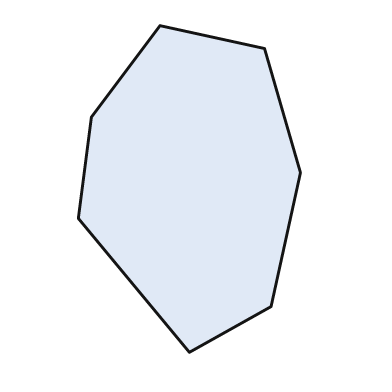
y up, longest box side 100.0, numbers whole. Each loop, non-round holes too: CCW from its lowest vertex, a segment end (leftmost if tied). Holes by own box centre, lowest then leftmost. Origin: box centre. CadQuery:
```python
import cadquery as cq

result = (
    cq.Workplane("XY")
    .moveTo(0.0, -50.0)
    .lineTo(25.0, -36.0)
    .lineTo(34.0, 5.0)
    .lineTo(23.0, 43.0)
    .lineTo(-9.0, 50.0)
    .lineTo(-30.0, 22.0)
    .lineTo(-34.0, -9.0)
    .close()
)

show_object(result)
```